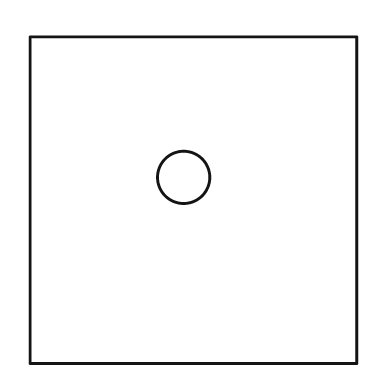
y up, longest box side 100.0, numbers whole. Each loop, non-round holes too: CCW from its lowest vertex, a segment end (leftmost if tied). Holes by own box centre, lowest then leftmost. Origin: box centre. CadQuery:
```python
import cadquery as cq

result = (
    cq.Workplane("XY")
    .moveTo(-50.0, -50.0)
    .lineTo(50.0, -50.0)
    .lineTo(50.0, 50.0)
    .lineTo(-50.0, 50.0)
    .close()
    .moveTo(-3.0, 7.0)
    .circle(8.0)
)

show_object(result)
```